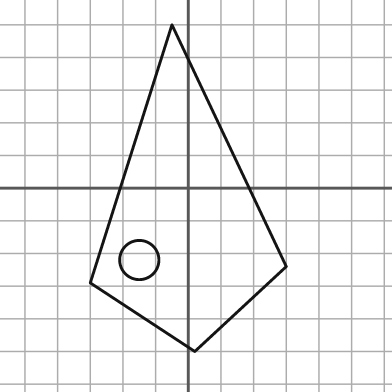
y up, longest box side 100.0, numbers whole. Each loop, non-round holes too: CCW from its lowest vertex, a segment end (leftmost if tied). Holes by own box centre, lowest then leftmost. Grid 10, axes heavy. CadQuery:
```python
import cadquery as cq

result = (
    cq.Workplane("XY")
    .moveTo(2.0, -50.0)
    .lineTo(30.0, -24.0)
    .lineTo(-5.0, 50.0)
    .lineTo(-30.0, -29.0)
    .close()
    .moveTo(-15.0, -22.0)
    .circle(6.0)
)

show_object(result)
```